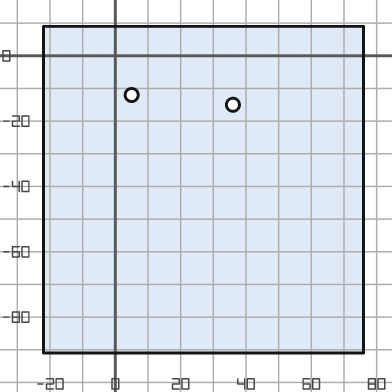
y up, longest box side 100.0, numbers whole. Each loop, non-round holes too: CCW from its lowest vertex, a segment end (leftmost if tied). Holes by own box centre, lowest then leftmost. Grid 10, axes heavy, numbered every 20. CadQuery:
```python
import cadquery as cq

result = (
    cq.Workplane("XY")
    .moveTo(-22.0, -91.0)
    .lineTo(76.0, -91.0)
    .lineTo(76.0, 9.0)
    .lineTo(-22.0, 9.0)
    .close()
    .moveTo(36.0, -15.0)
    .circle(2.0)
    .moveTo(5.0, -12.0)
    .circle(2.0)
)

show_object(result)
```